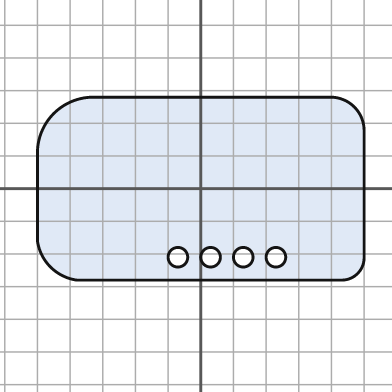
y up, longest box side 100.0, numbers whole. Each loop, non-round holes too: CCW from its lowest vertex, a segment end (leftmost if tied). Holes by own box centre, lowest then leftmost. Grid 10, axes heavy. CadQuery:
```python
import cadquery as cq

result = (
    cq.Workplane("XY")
    .moveTo(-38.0, -28.0)
    .lineTo(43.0, -28.0)
    .threePointArc((48.0, -26.0), (50.0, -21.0))
    .lineTo(50.0, 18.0)
    .threePointArc((47.0, 25.0), (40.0, 28.0))
    .lineTo(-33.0, 28.0)
    .threePointArc((-45.0, 23.0), (-50.0, 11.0))
    .lineTo(-50.0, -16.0)
    .threePointArc((-46.0, -24.0), (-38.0, -28.0))
    .close()
    .moveTo(-7.0, -21.0)
    .circle(3.0)
    .moveTo(3.0, -21.0)
    .circle(3.0)
    .moveTo(13.0, -21.0)
    .circle(3.0)
    .moveTo(23.0, -21.0)
    .circle(3.0)
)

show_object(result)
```